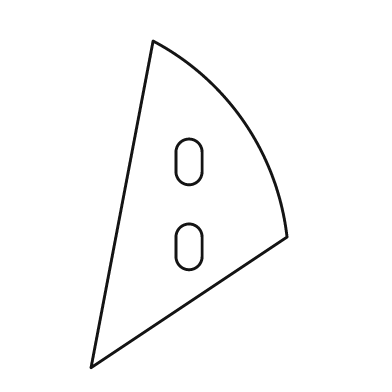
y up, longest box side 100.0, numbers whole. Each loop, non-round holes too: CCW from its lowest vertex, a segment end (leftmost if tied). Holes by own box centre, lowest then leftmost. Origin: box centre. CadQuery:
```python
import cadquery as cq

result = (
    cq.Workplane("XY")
    .moveTo(-30.0, -50.0)
    .lineTo(30.0, -10.0)
    .threePointArc((17.0, 25.0), (-11.0, 50.0))
    .close()
    .moveTo(-4.0, -16.0)
    .threePointArc((0.0, -20.0), (4.0, -16.0))
    .lineTo(4.0, -10.0)
    .threePointArc((0.0, -6.0), (-4.0, -10.0))
    .close()
    .moveTo(-4.0, 10.0)
    .threePointArc((0.0, 6.0), (4.0, 10.0))
    .lineTo(4.0, 16.0)
    .threePointArc((0.0, 20.0), (-4.0, 16.0))
    .close()
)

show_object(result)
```